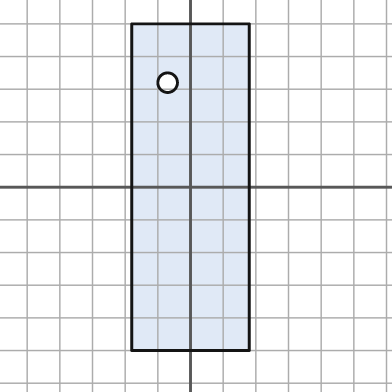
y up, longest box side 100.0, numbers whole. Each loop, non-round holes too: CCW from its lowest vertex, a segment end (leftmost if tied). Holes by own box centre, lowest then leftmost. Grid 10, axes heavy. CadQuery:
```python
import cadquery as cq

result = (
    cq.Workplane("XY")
    .moveTo(-18.0, -50.0)
    .lineTo(18.0, -50.0)
    .lineTo(18.0, 50.0)
    .lineTo(-18.0, 50.0)
    .close()
    .moveTo(-7.0, 32.0)
    .circle(3.0)
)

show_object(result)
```